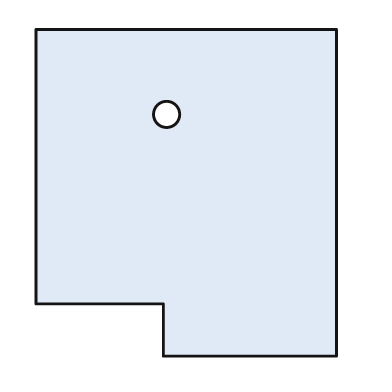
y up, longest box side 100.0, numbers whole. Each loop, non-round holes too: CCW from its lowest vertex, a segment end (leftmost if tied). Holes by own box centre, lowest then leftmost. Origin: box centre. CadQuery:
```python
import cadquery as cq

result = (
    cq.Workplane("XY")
    .moveTo(-7.0, -50.0)
    .lineTo(46.0, -50.0)
    .lineTo(46.0, 50.0)
    .lineTo(-46.0, 50.0)
    .lineTo(-46.0, -34.0)
    .lineTo(-7.0, -34.0)
    .close()
    .moveTo(-6.0, 24.0)
    .circle(4.0)
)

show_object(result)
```